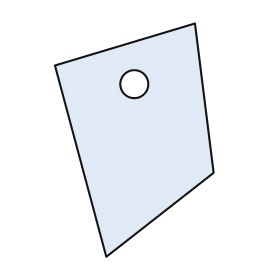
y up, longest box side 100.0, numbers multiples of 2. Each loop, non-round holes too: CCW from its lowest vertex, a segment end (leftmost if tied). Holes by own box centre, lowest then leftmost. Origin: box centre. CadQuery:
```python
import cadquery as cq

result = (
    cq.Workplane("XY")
    .moveTo(-12.0, -50.0)
    .lineTo(34.0, -14.0)
    .lineTo(26.0, 50.0)
    .lineTo(-34.0, 32.0)
    .close()
    .moveTo(0.0, 24.0)
    .circle(6.0)
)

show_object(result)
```